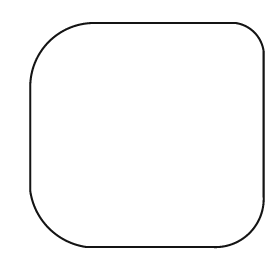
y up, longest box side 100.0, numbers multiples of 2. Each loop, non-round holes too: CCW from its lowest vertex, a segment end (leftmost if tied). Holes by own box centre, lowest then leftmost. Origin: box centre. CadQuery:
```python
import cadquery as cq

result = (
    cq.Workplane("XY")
    .moveTo(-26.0, -48.0)
    .lineTo(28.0, -48.0)
    .threePointArc((44.0, -42.0), (50.0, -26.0))
    .lineTo(50.0, 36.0)
    .threePointArc((46.0, 44.0), (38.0, 48.0))
    .lineTo(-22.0, 48.0)
    .threePointArc((-42.0, 40.0), (-50.0, 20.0))
    .lineTo(-50.0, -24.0)
    .threePointArc((-42.0, -40.0), (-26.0, -48.0))
    .close()
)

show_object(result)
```